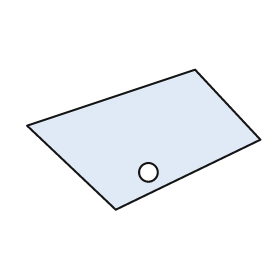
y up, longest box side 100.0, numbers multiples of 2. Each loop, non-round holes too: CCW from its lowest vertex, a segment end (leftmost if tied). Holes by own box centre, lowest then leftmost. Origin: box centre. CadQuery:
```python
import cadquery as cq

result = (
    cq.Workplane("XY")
    .moveTo(-12.0, -30.0)
    .lineTo(50.0, 0.0)
    .lineTo(22.0, 30.0)
    .lineTo(-50.0, 6.0)
    .close()
    .moveTo(2.0, -14.0)
    .circle(4.0)
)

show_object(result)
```